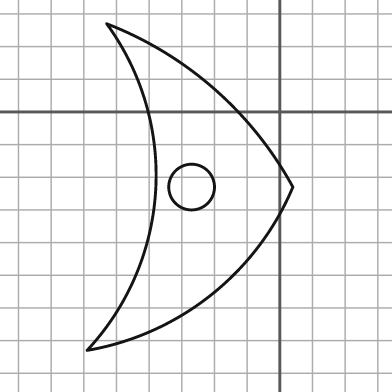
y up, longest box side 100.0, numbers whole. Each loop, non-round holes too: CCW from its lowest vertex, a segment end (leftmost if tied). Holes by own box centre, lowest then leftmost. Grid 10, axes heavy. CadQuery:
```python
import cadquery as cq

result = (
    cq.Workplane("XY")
    .moveTo(-59.0, -73.0)
    .threePointArc((-21.0, -56.0), (4.0, -23.0))
    .threePointArc((-20.0, 7.0), (-53.0, 27.0))
    .threePointArc((-38.0, -24.0), (-59.0, -73.0))
    .close()
    .moveTo(-27.0, -23.0)
    .circle(7.0)
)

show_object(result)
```